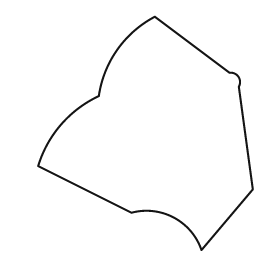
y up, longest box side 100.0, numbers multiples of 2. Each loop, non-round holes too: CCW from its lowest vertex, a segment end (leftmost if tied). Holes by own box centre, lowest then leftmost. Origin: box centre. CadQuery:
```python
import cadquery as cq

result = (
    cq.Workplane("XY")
    .moveTo(24.0, -50.0)
    .lineTo(46.0, -24.0)
    .lineTo(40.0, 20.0)
    .threePointArc((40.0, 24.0), (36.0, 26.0))
    .lineTo(4.0, 50.0)
    .threePointArc((-12.0, 36.0), (-20.0, 16.0))
    .threePointArc((-36.0, 4.0), (-46.0, -14.0))
    .lineTo(-6.0, -34.0)
    .threePointArc((12.0, -36.0), (24.0, -50.0))
    .close()
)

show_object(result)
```